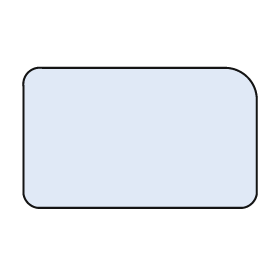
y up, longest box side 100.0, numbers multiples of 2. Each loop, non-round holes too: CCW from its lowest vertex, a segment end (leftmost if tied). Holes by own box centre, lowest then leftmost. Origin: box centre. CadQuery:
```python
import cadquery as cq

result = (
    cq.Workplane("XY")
    .moveTo(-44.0, -30.0)
    .lineTo(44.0, -30.0)
    .threePointArc((48.0, -28.0), (50.0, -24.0))
    .lineTo(50.0, 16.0)
    .threePointArc((46.0, 26.0), (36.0, 30.0))
    .lineTo(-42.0, 30.0)
    .threePointArc((-48.0, 28.0), (-50.0, 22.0))
    .lineTo(-50.0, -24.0)
    .threePointArc((-48.0, -28.0), (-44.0, -30.0))
    .close()
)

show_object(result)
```